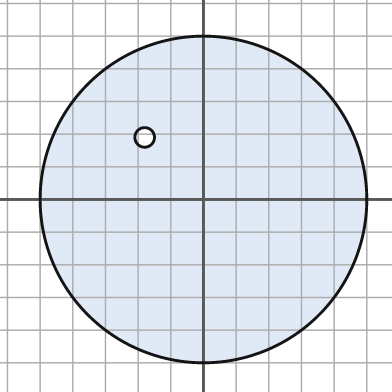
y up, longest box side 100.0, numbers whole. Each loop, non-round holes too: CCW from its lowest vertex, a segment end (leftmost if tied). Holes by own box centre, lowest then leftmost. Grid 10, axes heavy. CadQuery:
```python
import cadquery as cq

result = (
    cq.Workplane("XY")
    .moveTo(0.0, 0.0)
    .circle(50.0)
    .moveTo(-18.0, 19.0)
    .circle(3.0)
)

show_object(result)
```